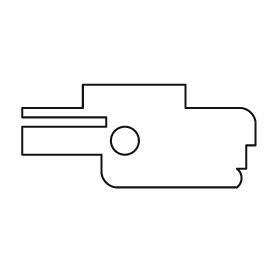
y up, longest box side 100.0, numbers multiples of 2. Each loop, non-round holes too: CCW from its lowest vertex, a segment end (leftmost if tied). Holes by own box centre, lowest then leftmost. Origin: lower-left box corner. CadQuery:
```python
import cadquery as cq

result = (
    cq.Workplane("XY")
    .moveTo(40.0, 0.0)
    .lineTo(92.0, 0.0)
    .threePointArc((94.0, 4.0), (92.0, 8.0))
    .lineTo(96.0, 8.0)
    .lineTo(96.0, 18.0)
    .lineTo(100.0, 18.0)
    .lineTo(100.0, 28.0)
    .threePointArc((98.0, 32.0), (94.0, 34.0))
    .lineTo(70.0, 34.0)
    .lineTo(70.0, 44.0)
    .lineTo(26.0, 44.0)
    .lineTo(26.0, 34.0)
    .lineTo(0.0, 34.0)
    .lineTo(0.0, 30.0)
    .lineTo(36.0, 30.0)
    .lineTo(36.0, 26.0)
    .lineTo(0.0, 26.0)
    .lineTo(0.0, 14.0)
    .lineTo(34.0, 14.0)
    .lineTo(34.0, 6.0)
    .threePointArc((36.0, 2.0), (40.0, 0.0))
    .close()
    .moveTo(44.0, 20.0)
    .circle(6.0)
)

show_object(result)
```